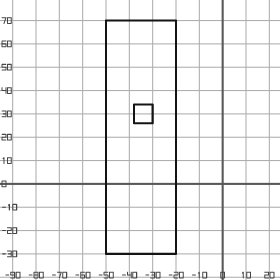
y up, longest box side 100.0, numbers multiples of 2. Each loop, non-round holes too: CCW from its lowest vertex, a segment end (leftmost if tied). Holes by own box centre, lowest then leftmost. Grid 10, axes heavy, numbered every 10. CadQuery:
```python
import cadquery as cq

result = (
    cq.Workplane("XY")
    .moveTo(-50.0, -30.0)
    .lineTo(-20.0, -30.0)
    .lineTo(-20.0, 70.0)
    .lineTo(-50.0, 70.0)
    .close()
    .moveTo(-38.0, 26.0)
    .lineTo(-30.0, 26.0)
    .lineTo(-30.0, 34.0)
    .lineTo(-38.0, 34.0)
    .close()
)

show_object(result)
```